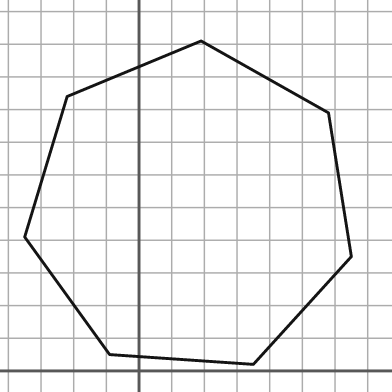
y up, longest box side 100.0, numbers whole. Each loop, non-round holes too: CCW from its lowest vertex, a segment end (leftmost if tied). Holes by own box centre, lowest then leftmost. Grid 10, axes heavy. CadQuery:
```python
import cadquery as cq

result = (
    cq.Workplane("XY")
    .moveTo(35.0, 2.0)
    .lineTo(65.0, 35.0)
    .lineTo(58.0, 79.0)
    .lineTo(19.0, 101.0)
    .lineTo(-22.0, 84.0)
    .lineTo(-35.0, 41.0)
    .lineTo(-9.0, 5.0)
    .close()
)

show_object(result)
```